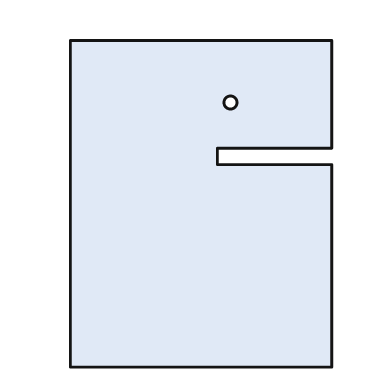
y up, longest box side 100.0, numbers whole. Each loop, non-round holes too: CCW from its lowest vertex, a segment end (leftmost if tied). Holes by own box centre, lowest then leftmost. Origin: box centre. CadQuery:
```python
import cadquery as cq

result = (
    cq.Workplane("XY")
    .moveTo(-40.0, -50.0)
    .lineTo(40.0, -50.0)
    .lineTo(40.0, 12.0)
    .lineTo(5.0, 12.0)
    .lineTo(5.0, 17.0)
    .lineTo(40.0, 17.0)
    .lineTo(40.0, 50.0)
    .lineTo(-40.0, 50.0)
    .close()
    .moveTo(9.0, 31.0)
    .circle(2.0)
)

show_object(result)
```